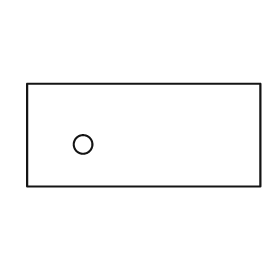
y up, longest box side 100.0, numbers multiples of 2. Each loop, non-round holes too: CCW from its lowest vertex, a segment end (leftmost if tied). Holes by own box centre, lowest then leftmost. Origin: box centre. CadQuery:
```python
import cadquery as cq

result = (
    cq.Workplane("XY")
    .moveTo(-50.0, -22.0)
    .lineTo(50.0, -22.0)
    .lineTo(50.0, 22.0)
    .lineTo(-50.0, 22.0)
    .close()
    .moveTo(-26.0, -4.0)
    .circle(4.0)
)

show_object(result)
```